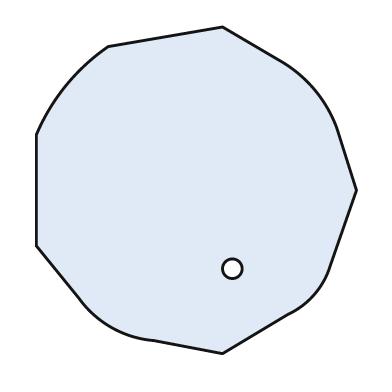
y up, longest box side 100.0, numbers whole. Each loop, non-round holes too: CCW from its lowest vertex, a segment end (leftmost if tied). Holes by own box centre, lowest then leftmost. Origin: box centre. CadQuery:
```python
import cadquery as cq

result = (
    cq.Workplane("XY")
    .moveTo(8.0, -50.0)
    .lineTo(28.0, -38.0)
    .threePointArc((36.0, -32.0), (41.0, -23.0))
    .lineTo(49.0, 0.0)
    .lineTo(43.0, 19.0)
    .threePointArc((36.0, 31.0), (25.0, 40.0))
    .lineTo(8.0, 50.0)
    .lineTo(-27.0, 44.0)
    .threePointArc((-40.0, 32.0), (-49.0, 17.0))
    .lineTo(-49.0, -17.0)
    .lineTo(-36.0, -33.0)
    .threePointArc((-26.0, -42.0), (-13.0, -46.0))
    .close()
    .moveTo(11.0, -24.0)
    .circle(3.0)
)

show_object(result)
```